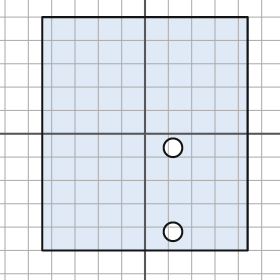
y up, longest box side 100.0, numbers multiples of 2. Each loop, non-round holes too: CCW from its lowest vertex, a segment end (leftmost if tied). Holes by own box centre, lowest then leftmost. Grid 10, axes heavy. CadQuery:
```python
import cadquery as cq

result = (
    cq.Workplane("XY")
    .moveTo(-44.0, -50.0)
    .lineTo(44.0, -50.0)
    .lineTo(44.0, 50.0)
    .lineTo(-44.0, 50.0)
    .close()
    .moveTo(12.0, -42.0)
    .circle(4.0)
    .moveTo(12.0, -6.0)
    .circle(4.0)
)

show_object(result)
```